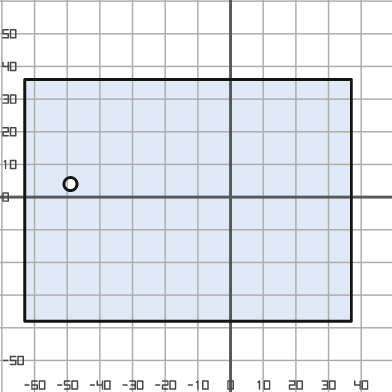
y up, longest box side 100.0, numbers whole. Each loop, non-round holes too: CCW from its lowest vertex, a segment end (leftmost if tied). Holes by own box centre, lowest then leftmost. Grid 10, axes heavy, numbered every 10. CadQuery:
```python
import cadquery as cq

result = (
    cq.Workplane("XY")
    .moveTo(-63.0, -38.0)
    .lineTo(37.0, -38.0)
    .lineTo(37.0, 36.0)
    .lineTo(-63.0, 36.0)
    .close()
    .moveTo(-49.0, 4.0)
    .circle(2.0)
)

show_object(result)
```